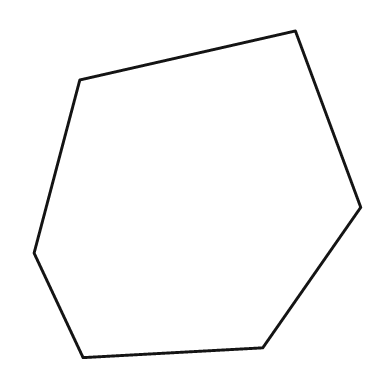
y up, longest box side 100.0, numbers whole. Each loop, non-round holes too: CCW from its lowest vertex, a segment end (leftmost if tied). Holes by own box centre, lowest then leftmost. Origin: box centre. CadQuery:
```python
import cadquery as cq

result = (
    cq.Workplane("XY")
    .moveTo(-35.0, -50.0)
    .lineTo(20.0, -47.0)
    .lineTo(50.0, -4.0)
    .lineTo(30.0, 50.0)
    .lineTo(-36.0, 35.0)
    .lineTo(-50.0, -18.0)
    .close()
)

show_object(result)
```